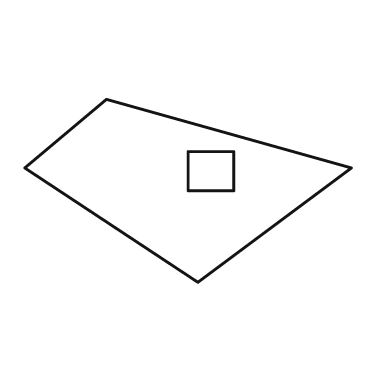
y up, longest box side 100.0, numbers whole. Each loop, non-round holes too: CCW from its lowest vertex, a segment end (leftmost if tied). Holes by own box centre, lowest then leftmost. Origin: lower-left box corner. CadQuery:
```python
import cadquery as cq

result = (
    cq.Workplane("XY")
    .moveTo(53.0, 0.0)
    .lineTo(100.0, 35.0)
    .lineTo(25.0, 56.0)
    .lineTo(0.0, 35.0)
    .close()
    .moveTo(50.0, 28.0)
    .lineTo(64.0, 28.0)
    .lineTo(64.0, 40.0)
    .lineTo(50.0, 40.0)
    .close()
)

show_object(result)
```